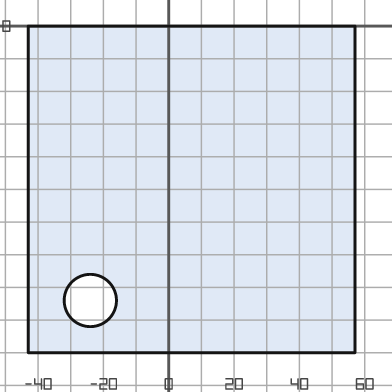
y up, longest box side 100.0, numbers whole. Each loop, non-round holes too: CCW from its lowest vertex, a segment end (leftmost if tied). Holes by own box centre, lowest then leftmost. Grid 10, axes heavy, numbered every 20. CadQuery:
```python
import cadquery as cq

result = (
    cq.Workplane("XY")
    .moveTo(-43.0, -100.0)
    .lineTo(57.0, -100.0)
    .lineTo(57.0, 0.0)
    .lineTo(-43.0, 0.0)
    .close()
    .moveTo(-24.0, -84.0)
    .circle(8.0)
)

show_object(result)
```